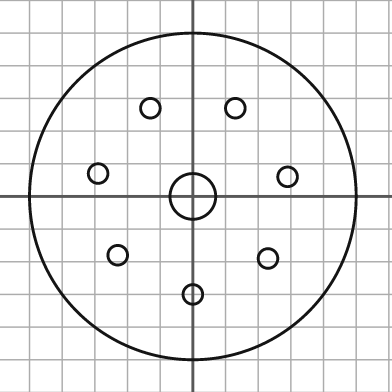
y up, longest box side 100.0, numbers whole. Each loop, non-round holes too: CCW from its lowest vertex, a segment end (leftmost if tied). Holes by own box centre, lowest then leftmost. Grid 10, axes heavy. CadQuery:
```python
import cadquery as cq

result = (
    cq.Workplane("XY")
    .moveTo(0.0, 0.0)
    .circle(50.0)
    .moveTo(0.0, -30.0)
    .circle(3.0)
    .moveTo(23.0, -19.0)
    .circle(3.0)
    .moveTo(-23.0, -18.0)
    .circle(3.0)
    .moveTo(0.0, 0.0)
    .circle(7.0)
    .moveTo(29.0, 6.0)
    .circle(3.0)
    .moveTo(-29.0, 7.0)
    .circle(3.0)
    .moveTo(-13.0, 27.0)
    .circle(3.0)
    .moveTo(13.0, 27.0)
    .circle(3.0)
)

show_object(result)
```